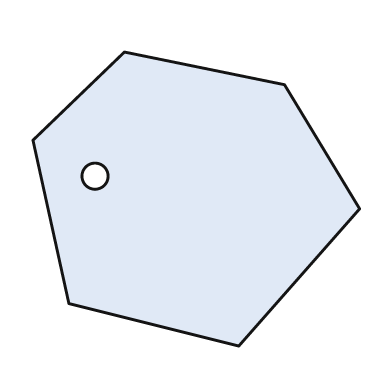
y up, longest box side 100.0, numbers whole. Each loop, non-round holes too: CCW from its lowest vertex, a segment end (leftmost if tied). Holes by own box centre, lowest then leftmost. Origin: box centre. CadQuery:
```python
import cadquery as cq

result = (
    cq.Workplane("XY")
    .moveTo(13.0, -45.0)
    .lineTo(50.0, -3.0)
    .lineTo(27.0, 35.0)
    .lineTo(-22.0, 45.0)
    .lineTo(-50.0, 18.0)
    .lineTo(-39.0, -32.0)
    .close()
    .moveTo(-31.0, 7.0)
    .circle(4.0)
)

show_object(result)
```